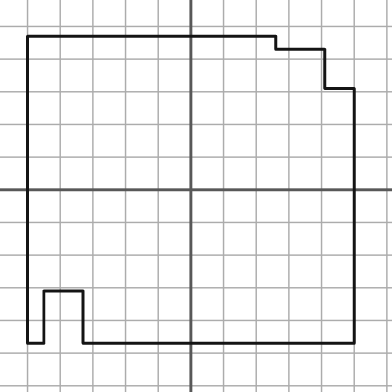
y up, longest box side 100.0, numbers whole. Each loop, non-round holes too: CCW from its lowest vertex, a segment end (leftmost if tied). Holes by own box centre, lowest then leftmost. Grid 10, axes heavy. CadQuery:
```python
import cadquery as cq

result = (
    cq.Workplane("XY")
    .moveTo(-50.0, -47.0)
    .lineTo(-45.0, -47.0)
    .lineTo(-45.0, -31.0)
    .lineTo(-33.0, -31.0)
    .lineTo(-33.0, -47.0)
    .lineTo(50.0, -47.0)
    .lineTo(50.0, 31.0)
    .lineTo(41.0, 31.0)
    .lineTo(41.0, 43.0)
    .lineTo(26.0, 43.0)
    .lineTo(26.0, 47.0)
    .lineTo(-50.0, 47.0)
    .close()
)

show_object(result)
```